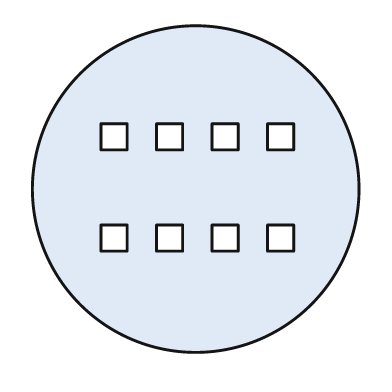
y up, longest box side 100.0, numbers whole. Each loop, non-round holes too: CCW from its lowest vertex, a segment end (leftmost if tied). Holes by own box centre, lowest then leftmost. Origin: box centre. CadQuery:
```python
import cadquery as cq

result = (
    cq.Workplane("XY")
    .moveTo(0.0, 0.0)
    .circle(50.0)
    .moveTo(-29.0, -19.0)
    .lineTo(-21.0, -19.0)
    .lineTo(-21.0, -11.0)
    .lineTo(-29.0, -11.0)
    .close()
    .moveTo(-12.0, -19.0)
    .lineTo(-4.0, -19.0)
    .lineTo(-4.0, -11.0)
    .lineTo(-12.0, -11.0)
    .close()
    .moveTo(5.0, -19.0)
    .lineTo(13.0, -19.0)
    .lineTo(13.0, -11.0)
    .lineTo(5.0, -11.0)
    .close()
    .moveTo(22.0, -19.0)
    .lineTo(30.0, -19.0)
    .lineTo(30.0, -11.0)
    .lineTo(22.0, -11.0)
    .close()
    .moveTo(-29.0, 12.0)
    .lineTo(-21.0, 12.0)
    .lineTo(-21.0, 20.0)
    .lineTo(-29.0, 20.0)
    .close()
    .moveTo(-12.0, 12.0)
    .lineTo(-4.0, 12.0)
    .lineTo(-4.0, 20.0)
    .lineTo(-12.0, 20.0)
    .close()
    .moveTo(5.0, 12.0)
    .lineTo(13.0, 12.0)
    .lineTo(13.0, 20.0)
    .lineTo(5.0, 20.0)
    .close()
    .moveTo(22.0, 12.0)
    .lineTo(30.0, 12.0)
    .lineTo(30.0, 20.0)
    .lineTo(22.0, 20.0)
    .close()
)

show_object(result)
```